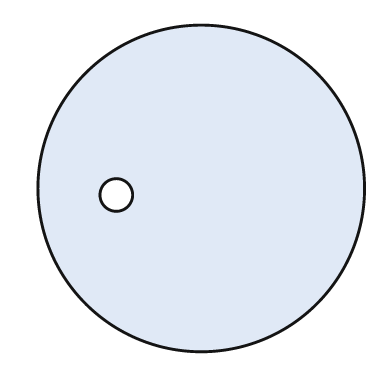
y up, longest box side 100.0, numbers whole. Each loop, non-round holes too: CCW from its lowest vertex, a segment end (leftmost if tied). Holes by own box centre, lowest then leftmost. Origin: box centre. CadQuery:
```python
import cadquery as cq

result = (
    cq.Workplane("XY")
    .moveTo(0.0, 0.0)
    .circle(50.0)
    .moveTo(-26.0, -2.0)
    .circle(5.0)
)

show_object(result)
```